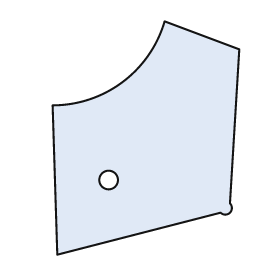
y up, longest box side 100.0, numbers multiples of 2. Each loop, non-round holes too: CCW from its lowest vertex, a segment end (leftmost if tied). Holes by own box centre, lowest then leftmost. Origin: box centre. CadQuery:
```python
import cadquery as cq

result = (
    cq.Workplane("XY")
    .moveTo(-38.0, -50.0)
    .lineTo(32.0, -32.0)
    .threePointArc((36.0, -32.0), (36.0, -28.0))
    .lineTo(40.0, 38.0)
    .lineTo(8.0, 50.0)
    .threePointArc((-10.0, 24.0), (-40.0, 14.0))
    .close()
    .moveTo(-16.0, -18.0)
    .circle(4.0)
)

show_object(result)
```